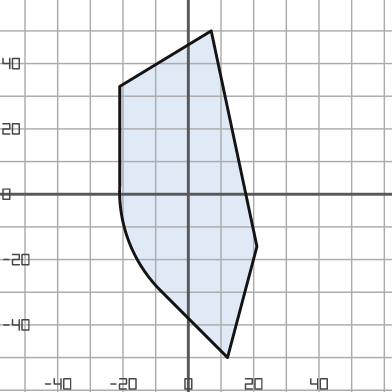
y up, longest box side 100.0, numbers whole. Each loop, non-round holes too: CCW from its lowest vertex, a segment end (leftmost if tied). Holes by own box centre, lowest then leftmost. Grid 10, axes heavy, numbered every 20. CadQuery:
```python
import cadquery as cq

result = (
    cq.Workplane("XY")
    .moveTo(12.0, -50.0)
    .lineTo(21.0, -16.0)
    .lineTo(7.0, 50.0)
    .lineTo(-21.0, 33.0)
    .lineTo(-21.0, 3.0)
    .threePointArc((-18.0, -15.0), (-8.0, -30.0))
    .close()
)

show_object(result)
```